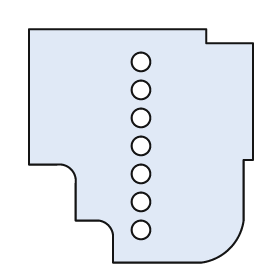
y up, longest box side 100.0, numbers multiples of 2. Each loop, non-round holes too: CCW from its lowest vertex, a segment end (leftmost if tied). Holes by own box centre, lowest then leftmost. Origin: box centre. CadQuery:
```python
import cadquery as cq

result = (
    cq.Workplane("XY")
    .moveTo(-12.0, -50.0)
    .lineTo(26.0, -50.0)
    .threePointArc((38.0, -44.0), (44.0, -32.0))
    .lineTo(44.0, -6.0)
    .lineTo(48.0, -6.0)
    .lineTo(48.0, 44.0)
    .lineTo(28.0, 44.0)
    .lineTo(28.0, 50.0)
    .lineTo(-48.0, 50.0)
    .lineTo(-48.0, -8.0)
    .lineTo(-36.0, -8.0)
    .threePointArc((-30.0, -10.0), (-28.0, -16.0))
    .lineTo(-28.0, -32.0)
    .lineTo(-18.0, -32.0)
    .threePointArc((-14.0, -34.0), (-12.0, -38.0))
    .close()
    .moveTo(0.0, -36.0)
    .circle(4.0)
    .moveTo(0.0, -24.0)
    .circle(4.0)
    .moveTo(0.0, -12.0)
    .circle(4.0)
    .moveTo(0.0, 0.0)
    .circle(4.0)
    .moveTo(0.0, 12.0)
    .circle(4.0)
    .moveTo(0.0, 24.0)
    .circle(4.0)
    .moveTo(0.0, 36.0)
    .circle(4.0)
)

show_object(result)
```